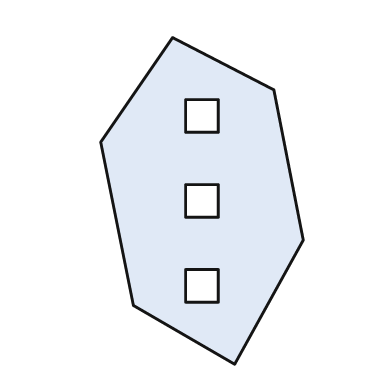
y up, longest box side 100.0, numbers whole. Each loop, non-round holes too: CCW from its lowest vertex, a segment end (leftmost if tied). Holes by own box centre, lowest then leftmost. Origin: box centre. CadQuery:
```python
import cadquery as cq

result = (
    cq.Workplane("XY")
    .moveTo(10.0, -50.0)
    .lineTo(31.0, -12.0)
    .lineTo(22.0, 34.0)
    .lineTo(-9.0, 50.0)
    .lineTo(-31.0, 18.0)
    .lineTo(-21.0, -32.0)
    .close()
    .moveTo(-5.0, -31.0)
    .lineTo(5.0, -31.0)
    .lineTo(5.0, -21.0)
    .lineTo(-5.0, -21.0)
    .close()
    .moveTo(-5.0, -5.0)
    .lineTo(5.0, -5.0)
    .lineTo(5.0, 5.0)
    .lineTo(-5.0, 5.0)
    .close()
    .moveTo(-5.0, 21.0)
    .lineTo(5.0, 21.0)
    .lineTo(5.0, 31.0)
    .lineTo(-5.0, 31.0)
    .close()
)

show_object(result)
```